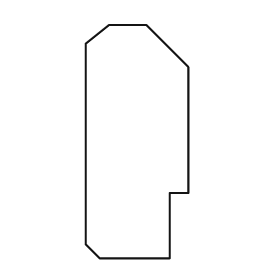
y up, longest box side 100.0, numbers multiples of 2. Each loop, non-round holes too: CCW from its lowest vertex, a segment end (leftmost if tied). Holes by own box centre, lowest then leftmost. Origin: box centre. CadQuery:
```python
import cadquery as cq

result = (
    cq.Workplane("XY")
    .moveTo(-16.0, -50.0)
    .lineTo(14.0, -50.0)
    .lineTo(14.0, -22.0)
    .lineTo(22.0, -22.0)
    .lineTo(22.0, 32.0)
    .lineTo(4.0, 50.0)
    .lineTo(-12.0, 50.0)
    .lineTo(-22.0, 42.0)
    .lineTo(-22.0, -44.0)
    .close()
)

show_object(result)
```